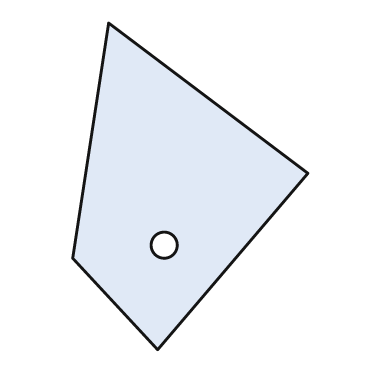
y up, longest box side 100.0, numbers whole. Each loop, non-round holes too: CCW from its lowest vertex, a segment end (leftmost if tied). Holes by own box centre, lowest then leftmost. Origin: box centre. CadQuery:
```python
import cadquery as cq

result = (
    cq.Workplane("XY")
    .moveTo(-10.0, -50.0)
    .lineTo(36.0, 4.0)
    .lineTo(-25.0, 50.0)
    .lineTo(-36.0, -22.0)
    .close()
    .moveTo(-8.0, -18.0)
    .circle(4.0)
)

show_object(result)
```